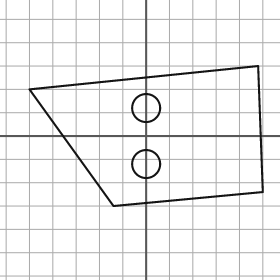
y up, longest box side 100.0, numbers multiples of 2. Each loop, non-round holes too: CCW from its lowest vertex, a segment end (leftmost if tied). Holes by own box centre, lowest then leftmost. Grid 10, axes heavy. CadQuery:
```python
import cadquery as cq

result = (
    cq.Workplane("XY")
    .moveTo(-14.0, -30.0)
    .lineTo(50.0, -24.0)
    .lineTo(48.0, 30.0)
    .lineTo(-50.0, 20.0)
    .close()
    .moveTo(0.0, -12.0)
    .circle(6.0)
    .moveTo(0.0, 12.0)
    .circle(6.0)
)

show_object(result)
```